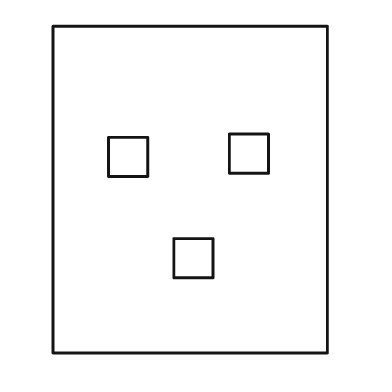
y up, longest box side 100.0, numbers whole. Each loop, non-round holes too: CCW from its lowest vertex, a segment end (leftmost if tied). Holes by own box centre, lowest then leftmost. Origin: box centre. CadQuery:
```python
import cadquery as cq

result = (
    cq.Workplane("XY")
    .moveTo(-42.0, -50.0)
    .lineTo(42.0, -50.0)
    .lineTo(42.0, 50.0)
    .lineTo(-42.0, 50.0)
    .close()
    .moveTo(-5.0, -27.0)
    .lineTo(7.0, -27.0)
    .lineTo(7.0, -15.0)
    .lineTo(-5.0, -15.0)
    .close()
    .moveTo(-25.0, 4.0)
    .lineTo(-13.0, 4.0)
    .lineTo(-13.0, 16.0)
    .lineTo(-25.0, 16.0)
    .close()
    .moveTo(12.0, 5.0)
    .lineTo(24.0, 5.0)
    .lineTo(24.0, 17.0)
    .lineTo(12.0, 17.0)
    .close()
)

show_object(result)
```